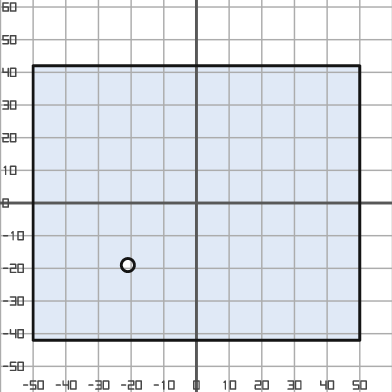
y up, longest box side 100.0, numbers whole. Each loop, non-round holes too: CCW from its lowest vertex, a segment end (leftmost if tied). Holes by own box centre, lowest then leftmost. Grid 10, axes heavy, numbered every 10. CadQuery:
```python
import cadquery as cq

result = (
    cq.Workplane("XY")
    .moveTo(-50.0, -42.0)
    .lineTo(50.0, -42.0)
    .lineTo(50.0, 42.0)
    .lineTo(-50.0, 42.0)
    .close()
    .moveTo(-21.0, -19.0)
    .circle(2.0)
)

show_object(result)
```